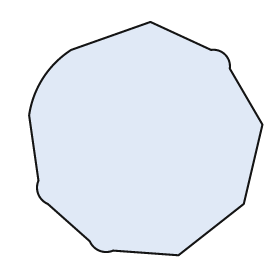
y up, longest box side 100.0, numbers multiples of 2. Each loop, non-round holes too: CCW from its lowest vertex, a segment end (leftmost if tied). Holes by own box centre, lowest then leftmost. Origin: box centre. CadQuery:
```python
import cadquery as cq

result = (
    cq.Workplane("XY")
    .moveTo(14.0, -50.0)
    .lineTo(42.0, -28.0)
    .lineTo(50.0, 6.0)
    .lineTo(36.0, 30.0)
    .threePointArc((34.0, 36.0), (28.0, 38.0))
    .lineTo(2.0, 50.0)
    .lineTo(-32.0, 38.0)
    .threePointArc((-44.0, 26.0), (-50.0, 10.0))
    .lineTo(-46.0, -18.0)
    .threePointArc((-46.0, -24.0), (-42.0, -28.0))
    .lineTo(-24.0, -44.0)
    .threePointArc((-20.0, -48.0), (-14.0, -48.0))
    .close()
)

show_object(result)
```